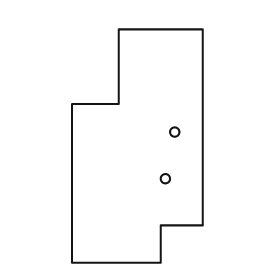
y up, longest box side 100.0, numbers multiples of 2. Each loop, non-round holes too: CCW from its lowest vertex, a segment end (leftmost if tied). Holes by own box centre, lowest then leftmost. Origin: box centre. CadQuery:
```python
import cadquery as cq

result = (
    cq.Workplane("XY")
    .moveTo(-28.0, -50.0)
    .lineTo(10.0, -50.0)
    .lineTo(10.0, -34.0)
    .lineTo(28.0, -34.0)
    .lineTo(28.0, 50.0)
    .lineTo(-8.0, 50.0)
    .lineTo(-8.0, 18.0)
    .lineTo(-28.0, 18.0)
    .close()
    .moveTo(12.0, -14.0)
    .circle(2.0)
    .moveTo(16.0, 6.0)
    .circle(2.0)
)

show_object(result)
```